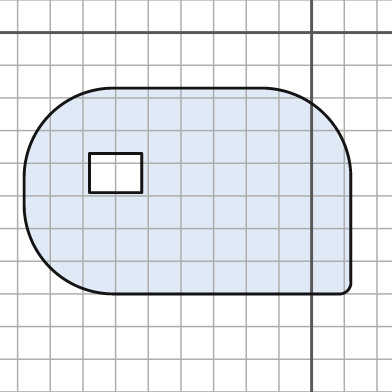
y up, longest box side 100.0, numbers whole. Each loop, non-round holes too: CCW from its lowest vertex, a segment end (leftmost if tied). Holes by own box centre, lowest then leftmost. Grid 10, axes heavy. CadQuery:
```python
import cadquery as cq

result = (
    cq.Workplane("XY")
    .moveTo(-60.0, -80.0)
    .lineTo(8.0, -80.0)
    .threePointArc((11.0, -79.0), (12.0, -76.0))
    .lineTo(12.0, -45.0)
    .threePointArc((4.0, -25.0), (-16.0, -17.0))
    .lineTo(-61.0, -17.0)
    .threePointArc((-80.0, -25.0), (-88.0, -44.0))
    .lineTo(-88.0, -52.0)
    .threePointArc((-80.0, -72.0), (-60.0, -80.0))
    .close()
    .moveTo(-68.0, -49.0)
    .lineTo(-52.0, -49.0)
    .lineTo(-52.0, -37.0)
    .lineTo(-68.0, -37.0)
    .close()
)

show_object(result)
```